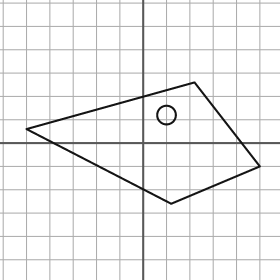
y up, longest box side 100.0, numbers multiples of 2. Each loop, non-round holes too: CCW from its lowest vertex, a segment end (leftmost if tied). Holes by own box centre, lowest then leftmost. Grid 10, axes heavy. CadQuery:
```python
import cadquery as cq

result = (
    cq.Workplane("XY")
    .moveTo(12.0, -26.0)
    .lineTo(50.0, -10.0)
    .lineTo(22.0, 26.0)
    .lineTo(-50.0, 6.0)
    .close()
    .moveTo(10.0, 12.0)
    .circle(4.0)
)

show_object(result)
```